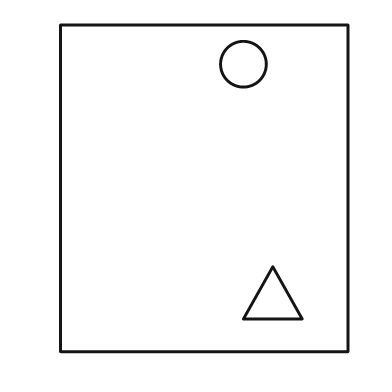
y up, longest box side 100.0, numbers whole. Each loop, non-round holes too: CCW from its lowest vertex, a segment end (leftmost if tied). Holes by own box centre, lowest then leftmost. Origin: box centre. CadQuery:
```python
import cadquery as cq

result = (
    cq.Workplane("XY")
    .moveTo(-44.0, -50.0)
    .lineTo(44.0, -50.0)
    .lineTo(44.0, 50.0)
    .lineTo(-44.0, 50.0)
    .close()
    .moveTo(12.0, -40.0)
    .lineTo(30.0, -40.0)
    .lineTo(21.0, -24.0)
    .close()
    .moveTo(12.0, 38.0)
    .circle(7.0)
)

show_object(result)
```